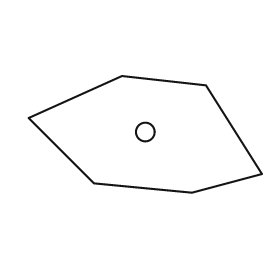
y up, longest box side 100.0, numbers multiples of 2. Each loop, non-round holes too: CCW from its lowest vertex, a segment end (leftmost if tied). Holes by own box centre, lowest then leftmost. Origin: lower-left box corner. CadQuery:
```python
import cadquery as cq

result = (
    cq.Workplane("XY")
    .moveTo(70.0, 0.0)
    .lineTo(100.0, 8.0)
    .lineTo(76.0, 46.0)
    .lineTo(40.0, 50.0)
    .lineTo(0.0, 32.0)
    .lineTo(28.0, 4.0)
    .close()
    .moveTo(50.0, 26.0)
    .circle(4.0)
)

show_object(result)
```